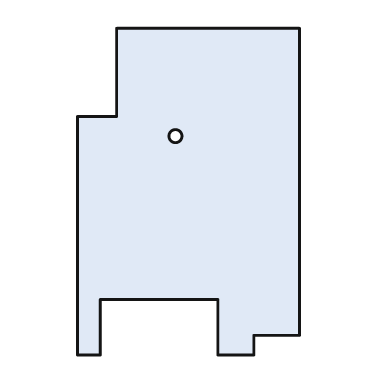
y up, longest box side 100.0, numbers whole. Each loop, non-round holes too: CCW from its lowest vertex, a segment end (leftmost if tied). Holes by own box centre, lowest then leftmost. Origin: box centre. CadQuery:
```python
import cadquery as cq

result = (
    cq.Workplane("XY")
    .moveTo(-34.0, -50.0)
    .lineTo(-27.0, -50.0)
    .lineTo(-27.0, -33.0)
    .lineTo(9.0, -33.0)
    .lineTo(9.0, -50.0)
    .lineTo(20.0, -50.0)
    .lineTo(20.0, -44.0)
    .lineTo(34.0, -44.0)
    .lineTo(34.0, 50.0)
    .lineTo(-22.0, 50.0)
    .lineTo(-22.0, 23.0)
    .lineTo(-34.0, 23.0)
    .close()
    .moveTo(-4.0, 17.0)
    .circle(2.0)
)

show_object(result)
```